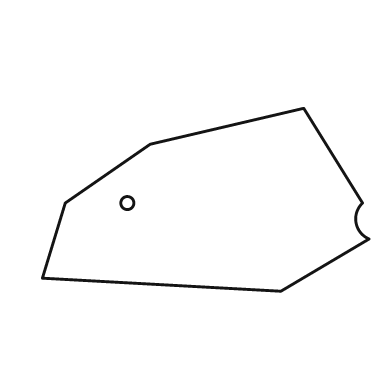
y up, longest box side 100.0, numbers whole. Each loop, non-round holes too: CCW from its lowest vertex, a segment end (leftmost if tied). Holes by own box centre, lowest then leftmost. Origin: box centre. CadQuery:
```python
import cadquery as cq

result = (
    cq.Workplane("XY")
    .moveTo(23.0, -28.0)
    .lineTo(50.0, -12.0)
    .threePointArc((46.0, -7.0), (48.0, -1.0))
    .lineTo(30.0, 28.0)
    .lineTo(-17.0, 17.0)
    .lineTo(-43.0, -1.0)
    .lineTo(-50.0, -24.0)
    .close()
    .moveTo(-24.0, -1.0)
    .circle(2.0)
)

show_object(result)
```